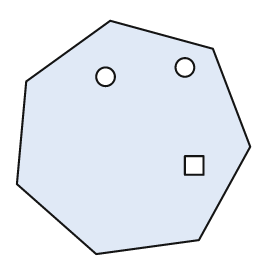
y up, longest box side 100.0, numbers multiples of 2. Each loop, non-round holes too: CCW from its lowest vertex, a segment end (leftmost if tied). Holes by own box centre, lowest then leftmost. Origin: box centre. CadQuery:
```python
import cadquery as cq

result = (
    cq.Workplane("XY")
    .moveTo(-16.0, -50.0)
    .lineTo(28.0, -44.0)
    .lineTo(50.0, -4.0)
    .lineTo(34.0, 38.0)
    .lineTo(-10.0, 50.0)
    .lineTo(-46.0, 24.0)
    .lineTo(-50.0, -20.0)
    .close()
    .moveTo(22.0, -16.0)
    .lineTo(30.0, -16.0)
    .lineTo(30.0, -8.0)
    .lineTo(22.0, -8.0)
    .close()
    .moveTo(-12.0, 26.0)
    .circle(4.0)
    .moveTo(22.0, 30.0)
    .circle(4.0)
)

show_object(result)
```